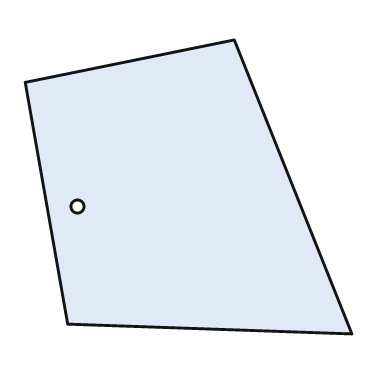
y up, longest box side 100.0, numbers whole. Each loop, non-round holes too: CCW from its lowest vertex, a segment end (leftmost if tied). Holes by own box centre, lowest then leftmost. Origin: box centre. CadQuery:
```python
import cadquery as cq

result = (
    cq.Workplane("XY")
    .moveTo(50.0, -45.0)
    .lineTo(14.0, 45.0)
    .lineTo(-50.0, 32.0)
    .lineTo(-37.0, -42.0)
    .close()
    .moveTo(-34.0, -6.0)
    .circle(2.0)
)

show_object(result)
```